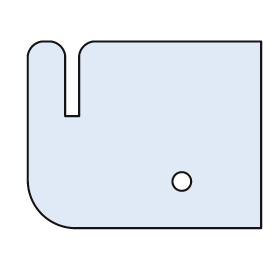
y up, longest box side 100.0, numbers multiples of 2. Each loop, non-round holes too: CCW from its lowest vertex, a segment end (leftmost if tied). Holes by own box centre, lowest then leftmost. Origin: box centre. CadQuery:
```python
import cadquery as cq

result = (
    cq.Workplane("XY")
    .moveTo(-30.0, -40.0)
    .lineTo(50.0, -40.0)
    .lineTo(50.0, 40.0)
    .lineTo(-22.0, 40.0)
    .threePointArc((-26.0, 38.0), (-28.0, 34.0))
    .lineTo(-28.0, 8.0)
    .lineTo(-34.0, 8.0)
    .lineTo(-34.0, 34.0)
    .threePointArc((-36.0, 38.0), (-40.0, 40.0))
    .lineTo(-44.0, 40.0)
    .threePointArc((-48.0, 38.0), (-50.0, 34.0))
    .lineTo(-50.0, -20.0)
    .threePointArc((-44.0, -34.0), (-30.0, -40.0))
    .close()
    .moveTo(16.0, -20.0)
    .circle(4.0)
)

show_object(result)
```